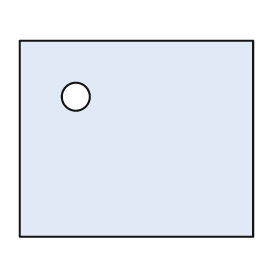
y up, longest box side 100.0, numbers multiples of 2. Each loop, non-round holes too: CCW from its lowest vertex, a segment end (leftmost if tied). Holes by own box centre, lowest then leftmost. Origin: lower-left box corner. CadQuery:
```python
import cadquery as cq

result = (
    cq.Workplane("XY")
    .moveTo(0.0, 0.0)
    .lineTo(100.0, 0.0)
    .lineTo(100.0, 84.0)
    .lineTo(0.0, 84.0)
    .close()
    .moveTo(24.0, 60.0)
    .circle(6.0)
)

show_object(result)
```